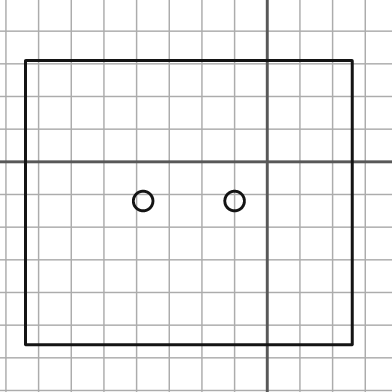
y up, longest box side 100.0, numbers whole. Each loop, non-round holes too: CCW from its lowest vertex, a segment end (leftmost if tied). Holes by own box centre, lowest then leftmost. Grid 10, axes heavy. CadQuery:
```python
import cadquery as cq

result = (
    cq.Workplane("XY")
    .moveTo(-74.0, -56.0)
    .lineTo(26.0, -56.0)
    .lineTo(26.0, 31.0)
    .lineTo(-74.0, 31.0)
    .close()
    .moveTo(-38.0, -12.0)
    .circle(3.0)
    .moveTo(-10.0, -12.0)
    .circle(3.0)
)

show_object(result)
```